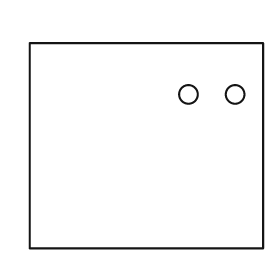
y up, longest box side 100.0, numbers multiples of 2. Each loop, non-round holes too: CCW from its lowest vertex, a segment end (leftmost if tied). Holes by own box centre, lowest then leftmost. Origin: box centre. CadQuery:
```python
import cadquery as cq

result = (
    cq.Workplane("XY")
    .moveTo(-50.0, -44.0)
    .lineTo(50.0, -44.0)
    .lineTo(50.0, 44.0)
    .lineTo(-50.0, 44.0)
    .close()
    .moveTo(18.0, 22.0)
    .circle(4.0)
    .moveTo(38.0, 22.0)
    .circle(4.0)
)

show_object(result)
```